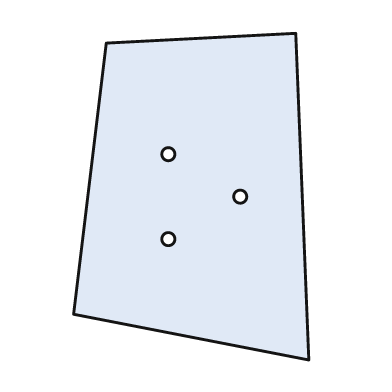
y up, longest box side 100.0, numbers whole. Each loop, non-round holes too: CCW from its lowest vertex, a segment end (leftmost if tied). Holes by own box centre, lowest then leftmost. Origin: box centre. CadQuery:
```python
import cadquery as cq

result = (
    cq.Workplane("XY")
    .moveTo(36.0, -50.0)
    .lineTo(32.0, 50.0)
    .lineTo(-26.0, 47.0)
    .lineTo(-36.0, -36.0)
    .close()
    .moveTo(-7.0, -13.0)
    .circle(2.0)
    .moveTo(15.0, 0.0)
    .circle(2.0)
    .moveTo(-7.0, 13.0)
    .circle(2.0)
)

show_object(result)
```